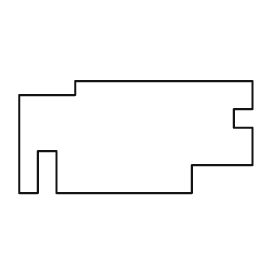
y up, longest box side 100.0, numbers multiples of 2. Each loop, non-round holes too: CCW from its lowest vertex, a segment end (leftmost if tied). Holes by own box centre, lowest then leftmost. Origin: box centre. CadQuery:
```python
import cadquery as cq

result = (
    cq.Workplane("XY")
    .moveTo(-50.0, -24.0)
    .lineTo(-42.0, -24.0)
    .lineTo(-42.0, -6.0)
    .lineTo(-34.0, -6.0)
    .lineTo(-34.0, -24.0)
    .lineTo(24.0, -24.0)
    .lineTo(24.0, -12.0)
    .lineTo(50.0, -12.0)
    .lineTo(50.0, 4.0)
    .lineTo(42.0, 4.0)
    .lineTo(42.0, 12.0)
    .lineTo(50.0, 12.0)
    .lineTo(50.0, 24.0)
    .lineTo(-26.0, 24.0)
    .lineTo(-26.0, 18.0)
    .lineTo(-50.0, 18.0)
    .close()
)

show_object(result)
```